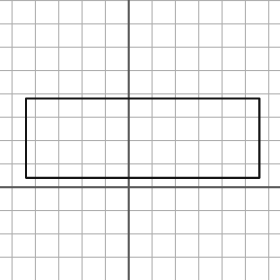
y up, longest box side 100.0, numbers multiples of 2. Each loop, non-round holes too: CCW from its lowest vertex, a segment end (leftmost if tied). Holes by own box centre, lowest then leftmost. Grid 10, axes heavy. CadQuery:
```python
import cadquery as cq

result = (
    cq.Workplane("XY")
    .moveTo(-44.0, 4.0)
    .lineTo(56.0, 4.0)
    .lineTo(56.0, 38.0)
    .lineTo(-44.0, 38.0)
    .close()
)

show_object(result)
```